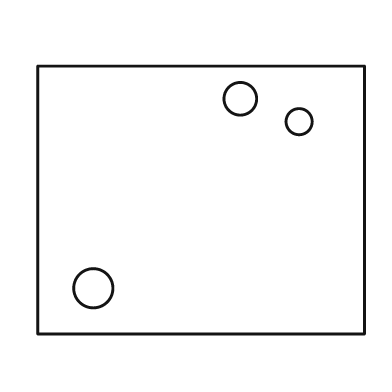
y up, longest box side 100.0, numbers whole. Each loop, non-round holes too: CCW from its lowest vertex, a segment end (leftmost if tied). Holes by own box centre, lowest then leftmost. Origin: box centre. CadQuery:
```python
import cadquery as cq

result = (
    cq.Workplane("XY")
    .moveTo(-50.0, -41.0)
    .lineTo(50.0, -41.0)
    .lineTo(50.0, 41.0)
    .lineTo(-50.0, 41.0)
    .close()
    .moveTo(-33.0, -27.0)
    .circle(6.0)
    .moveTo(30.0, 24.0)
    .circle(4.0)
    .moveTo(12.0, 31.0)
    .circle(5.0)
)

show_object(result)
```